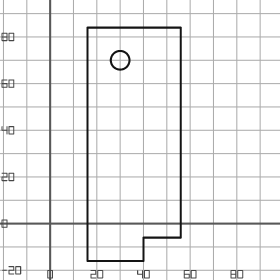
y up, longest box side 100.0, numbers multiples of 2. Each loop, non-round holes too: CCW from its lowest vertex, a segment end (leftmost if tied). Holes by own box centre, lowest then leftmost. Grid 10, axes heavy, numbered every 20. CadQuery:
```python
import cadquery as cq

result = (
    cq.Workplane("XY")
    .moveTo(16.0, -16.0)
    .lineTo(40.0, -16.0)
    .lineTo(40.0, -6.0)
    .lineTo(56.0, -6.0)
    .lineTo(56.0, 84.0)
    .lineTo(16.0, 84.0)
    .close()
    .moveTo(30.0, 70.0)
    .circle(4.0)
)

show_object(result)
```